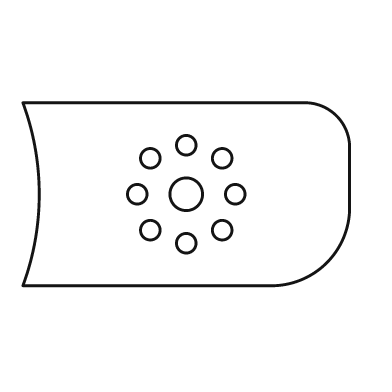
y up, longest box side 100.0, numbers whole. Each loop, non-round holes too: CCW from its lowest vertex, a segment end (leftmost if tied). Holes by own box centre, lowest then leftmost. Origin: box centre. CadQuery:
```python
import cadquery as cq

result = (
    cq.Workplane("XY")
    .moveTo(-50.0, -28.0)
    .lineTo(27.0, -28.0)
    .threePointArc((43.0, -21.0), (50.0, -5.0))
    .lineTo(50.0, 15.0)
    .threePointArc((46.0, 24.0), (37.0, 28.0))
    .lineTo(-50.0, 28.0)
    .threePointArc((-45.0, 0.0), (-50.0, -28.0))
    .close()
    .moveTo(0.0, -15.0)
    .circle(3.0)
    .moveTo(-11.0, -11.0)
    .circle(3.0)
    .moveTo(11.0, -11.0)
    .circle(3.0)
    .moveTo(-15.0, 0.0)
    .circle(3.0)
    .moveTo(0.0, 0.0)
    .circle(5.0)
    .moveTo(15.0, 0.0)
    .circle(3.0)
    .moveTo(-11.0, 11.0)
    .circle(3.0)
    .moveTo(11.0, 11.0)
    .circle(3.0)
    .moveTo(0.0, 15.0)
    .circle(3.0)
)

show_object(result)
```